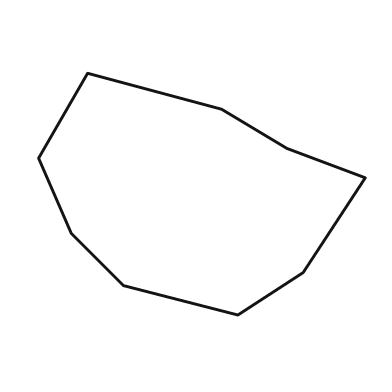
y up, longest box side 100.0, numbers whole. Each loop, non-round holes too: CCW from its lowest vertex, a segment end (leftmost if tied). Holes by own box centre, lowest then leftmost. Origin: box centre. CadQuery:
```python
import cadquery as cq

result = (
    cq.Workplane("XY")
    .moveTo(11.0, -37.0)
    .lineTo(31.0, -24.0)
    .lineTo(50.0, 5.0)
    .lineTo(26.0, 14.0)
    .lineTo(6.0, 26.0)
    .lineTo(-35.0, 37.0)
    .lineTo(-50.0, 11.0)
    .lineTo(-40.0, -12.0)
    .lineTo(-24.0, -28.0)
    .close()
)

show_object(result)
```